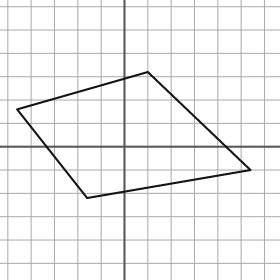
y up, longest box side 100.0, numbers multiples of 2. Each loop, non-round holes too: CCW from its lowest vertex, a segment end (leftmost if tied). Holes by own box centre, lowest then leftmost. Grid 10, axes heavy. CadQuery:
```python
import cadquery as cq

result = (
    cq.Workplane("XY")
    .moveTo(-16.0, -22.0)
    .lineTo(54.0, -10.0)
    .lineTo(10.0, 32.0)
    .lineTo(-46.0, 16.0)
    .close()
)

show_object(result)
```